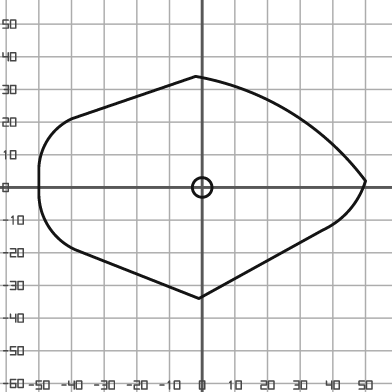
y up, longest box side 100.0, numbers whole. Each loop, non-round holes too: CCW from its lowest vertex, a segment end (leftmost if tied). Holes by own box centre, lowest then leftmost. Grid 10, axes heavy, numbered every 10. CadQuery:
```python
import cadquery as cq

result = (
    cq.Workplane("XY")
    .moveTo(-1.0, -34.0)
    .lineTo(37.0, -13.0)
    .threePointArc((45.0, -7.0), (50.0, 2.0))
    .threePointArc((27.0, 23.0), (-2.0, 34.0))
    .lineTo(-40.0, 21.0)
    .threePointArc((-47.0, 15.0), (-50.0, 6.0))
    .lineTo(-50.0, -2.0)
    .threePointArc((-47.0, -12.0), (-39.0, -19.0))
    .close()
    .moveTo(0.0, 0.0)
    .circle(3.0)
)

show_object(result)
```